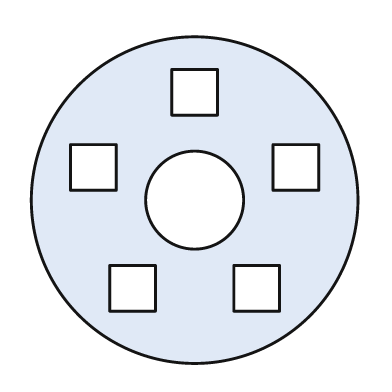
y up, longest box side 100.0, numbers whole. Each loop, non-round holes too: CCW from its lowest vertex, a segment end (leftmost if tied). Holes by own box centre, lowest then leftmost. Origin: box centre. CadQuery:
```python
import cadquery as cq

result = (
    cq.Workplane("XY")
    .moveTo(0.0, 0.0)
    .circle(50.0)
    .moveTo(-26.0, -34.0)
    .lineTo(-12.0, -34.0)
    .lineTo(-12.0, -20.0)
    .lineTo(-26.0, -20.0)
    .close()
    .moveTo(12.0, -34.0)
    .lineTo(26.0, -34.0)
    .lineTo(26.0, -20.0)
    .lineTo(12.0, -20.0)
    .close()
    .moveTo(0.0, 0.0)
    .circle(15.0)
    .moveTo(-38.0, 3.0)
    .lineTo(-24.0, 3.0)
    .lineTo(-24.0, 17.0)
    .lineTo(-38.0, 17.0)
    .close()
    .moveTo(24.0, 3.0)
    .lineTo(38.0, 3.0)
    .lineTo(38.0, 17.0)
    .lineTo(24.0, 17.0)
    .close()
    .moveTo(-7.0, 26.0)
    .lineTo(7.0, 26.0)
    .lineTo(7.0, 40.0)
    .lineTo(-7.0, 40.0)
    .close()
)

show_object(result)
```